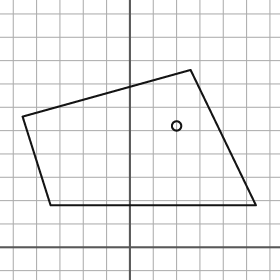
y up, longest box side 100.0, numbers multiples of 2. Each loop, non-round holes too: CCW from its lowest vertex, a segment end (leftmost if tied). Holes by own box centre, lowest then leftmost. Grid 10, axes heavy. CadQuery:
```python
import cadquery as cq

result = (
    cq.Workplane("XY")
    .moveTo(-34.0, 18.0)
    .lineTo(54.0, 18.0)
    .lineTo(26.0, 76.0)
    .lineTo(-46.0, 56.0)
    .close()
    .moveTo(20.0, 52.0)
    .circle(2.0)
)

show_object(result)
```